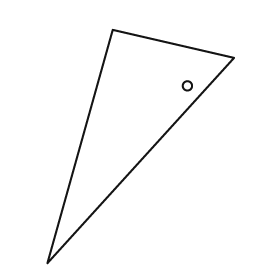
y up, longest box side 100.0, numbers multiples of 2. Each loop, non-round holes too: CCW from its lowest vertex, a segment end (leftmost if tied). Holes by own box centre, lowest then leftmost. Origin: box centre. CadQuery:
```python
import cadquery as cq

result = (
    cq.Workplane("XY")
    .moveTo(-40.0, -50.0)
    .lineTo(40.0, 38.0)
    .lineTo(-12.0, 50.0)
    .close()
    .moveTo(20.0, 26.0)
    .circle(2.0)
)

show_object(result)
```